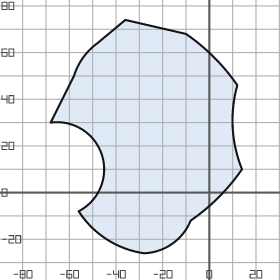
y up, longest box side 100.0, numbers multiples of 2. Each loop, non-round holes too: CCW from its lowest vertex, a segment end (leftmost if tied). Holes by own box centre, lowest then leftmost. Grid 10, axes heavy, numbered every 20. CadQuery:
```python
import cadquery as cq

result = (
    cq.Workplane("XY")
    .moveTo(-28.0, -26.0)
    .threePointArc((-16.0, -22.0), (-8.0, -12.0))
    .threePointArc((4.0, -2.0), (14.0, 10.0))
    .threePointArc((10.0, 28.0), (12.0, 46.0))
    .threePointArc((2.0, 58.0), (-10.0, 68.0))
    .lineTo(-36.0, 74.0)
    .lineTo(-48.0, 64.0)
    .threePointArc((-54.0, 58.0), (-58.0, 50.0))
    .lineTo(-68.0, 30.0)
    .threePointArc((-46.0, 16.0), (-56.0, -8.0))
    .threePointArc((-44.0, -20.0), (-28.0, -26.0))
    .close()
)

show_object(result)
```